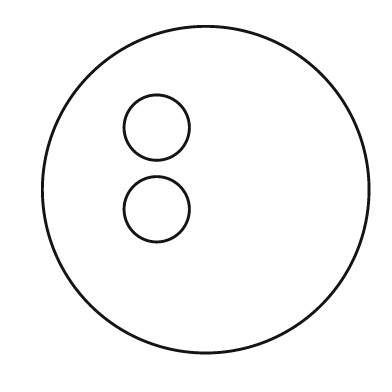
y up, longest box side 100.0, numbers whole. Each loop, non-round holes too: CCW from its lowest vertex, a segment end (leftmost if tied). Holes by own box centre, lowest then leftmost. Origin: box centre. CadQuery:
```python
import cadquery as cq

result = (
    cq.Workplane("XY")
    .moveTo(0.0, 0.0)
    .circle(50.0)
    .moveTo(-15.0, -6.0)
    .circle(10.0)
    .moveTo(-15.0, 19.0)
    .circle(10.0)
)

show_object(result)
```